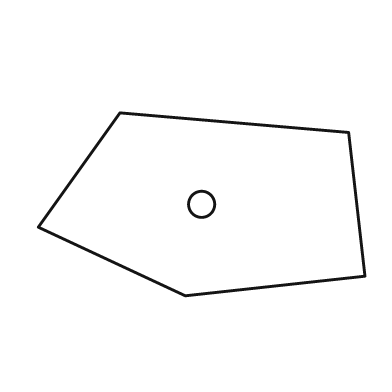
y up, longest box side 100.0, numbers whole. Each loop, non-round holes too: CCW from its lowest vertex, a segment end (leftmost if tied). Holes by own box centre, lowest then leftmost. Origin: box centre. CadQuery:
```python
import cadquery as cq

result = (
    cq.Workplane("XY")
    .moveTo(-5.0, -28.0)
    .lineTo(50.0, -22.0)
    .lineTo(45.0, 22.0)
    .lineTo(-25.0, 28.0)
    .lineTo(-50.0, -7.0)
    .close()
    .moveTo(0.0, 0.0)
    .circle(4.0)
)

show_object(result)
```